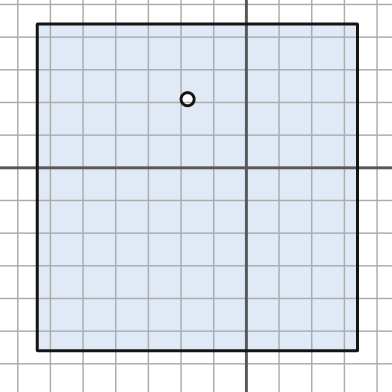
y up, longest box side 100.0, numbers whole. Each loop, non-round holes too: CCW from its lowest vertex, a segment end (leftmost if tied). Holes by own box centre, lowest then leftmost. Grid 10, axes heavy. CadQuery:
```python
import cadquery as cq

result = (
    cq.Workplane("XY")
    .moveTo(-64.0, -56.0)
    .lineTo(34.0, -56.0)
    .lineTo(34.0, 44.0)
    .lineTo(-64.0, 44.0)
    .close()
    .moveTo(-18.0, 21.0)
    .circle(2.0)
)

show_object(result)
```